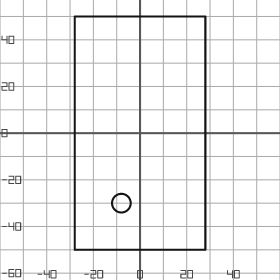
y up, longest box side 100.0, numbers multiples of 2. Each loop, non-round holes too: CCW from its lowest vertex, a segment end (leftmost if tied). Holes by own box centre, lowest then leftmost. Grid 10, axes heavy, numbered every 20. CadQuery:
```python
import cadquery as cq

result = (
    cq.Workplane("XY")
    .moveTo(-28.0, -50.0)
    .lineTo(28.0, -50.0)
    .lineTo(28.0, 50.0)
    .lineTo(-28.0, 50.0)
    .close()
    .moveTo(-8.0, -30.0)
    .circle(4.0)
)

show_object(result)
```